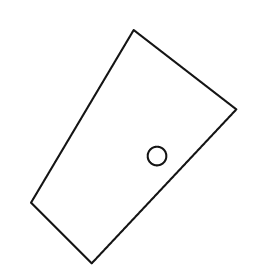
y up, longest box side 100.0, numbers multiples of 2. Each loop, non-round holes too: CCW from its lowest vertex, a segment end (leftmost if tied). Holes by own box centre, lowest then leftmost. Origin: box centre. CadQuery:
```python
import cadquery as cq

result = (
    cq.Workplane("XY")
    .moveTo(-18.0, -50.0)
    .lineTo(44.0, 16.0)
    .lineTo(0.0, 50.0)
    .lineTo(-44.0, -24.0)
    .close()
    .moveTo(10.0, -4.0)
    .circle(4.0)
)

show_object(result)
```